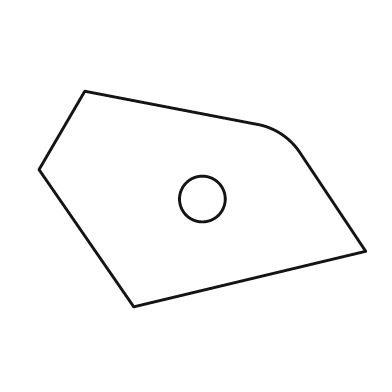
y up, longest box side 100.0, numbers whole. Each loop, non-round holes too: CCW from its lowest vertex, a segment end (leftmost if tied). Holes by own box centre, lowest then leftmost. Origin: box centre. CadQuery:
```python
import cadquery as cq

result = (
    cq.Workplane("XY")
    .moveTo(-21.0, -33.0)
    .lineTo(50.0, -16.0)
    .lineTo(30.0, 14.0)
    .threePointArc((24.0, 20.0), (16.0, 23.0))
    .lineTo(-36.0, 33.0)
    .lineTo(-50.0, 9.0)
    .close()
    .moveTo(0.0, 0.0)
    .circle(7.0)
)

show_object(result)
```